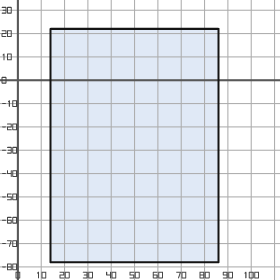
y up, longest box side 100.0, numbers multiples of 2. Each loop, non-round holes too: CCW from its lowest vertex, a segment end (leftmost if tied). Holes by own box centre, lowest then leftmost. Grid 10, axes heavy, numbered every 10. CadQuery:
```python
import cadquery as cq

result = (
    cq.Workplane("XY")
    .moveTo(14.0, -78.0)
    .lineTo(86.0, -78.0)
    .lineTo(86.0, 22.0)
    .lineTo(14.0, 22.0)
    .close()
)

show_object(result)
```